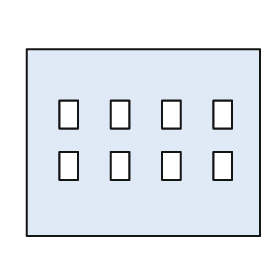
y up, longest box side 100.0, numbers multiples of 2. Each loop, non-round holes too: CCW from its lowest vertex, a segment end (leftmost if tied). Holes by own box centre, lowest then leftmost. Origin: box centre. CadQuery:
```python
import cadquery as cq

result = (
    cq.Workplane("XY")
    .moveTo(-50.0, -40.0)
    .lineTo(50.0, -40.0)
    .lineTo(50.0, 40.0)
    .lineTo(-50.0, 40.0)
    .close()
    .moveTo(-36.0, -16.0)
    .lineTo(-28.0, -16.0)
    .lineTo(-28.0, -4.0)
    .lineTo(-36.0, -4.0)
    .close()
    .moveTo(-14.0, -16.0)
    .lineTo(-6.0, -16.0)
    .lineTo(-6.0, -4.0)
    .lineTo(-14.0, -4.0)
    .close()
    .moveTo(8.0, -16.0)
    .lineTo(16.0, -16.0)
    .lineTo(16.0, -4.0)
    .lineTo(8.0, -4.0)
    .close()
    .moveTo(30.0, -16.0)
    .lineTo(38.0, -16.0)
    .lineTo(38.0, -4.0)
    .lineTo(30.0, -4.0)
    .close()
    .moveTo(-36.0, 6.0)
    .lineTo(-28.0, 6.0)
    .lineTo(-28.0, 18.0)
    .lineTo(-36.0, 18.0)
    .close()
    .moveTo(-14.0, 6.0)
    .lineTo(-6.0, 6.0)
    .lineTo(-6.0, 18.0)
    .lineTo(-14.0, 18.0)
    .close()
    .moveTo(8.0, 6.0)
    .lineTo(16.0, 6.0)
    .lineTo(16.0, 18.0)
    .lineTo(8.0, 18.0)
    .close()
    .moveTo(30.0, 6.0)
    .lineTo(38.0, 6.0)
    .lineTo(38.0, 18.0)
    .lineTo(30.0, 18.0)
    .close()
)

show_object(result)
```